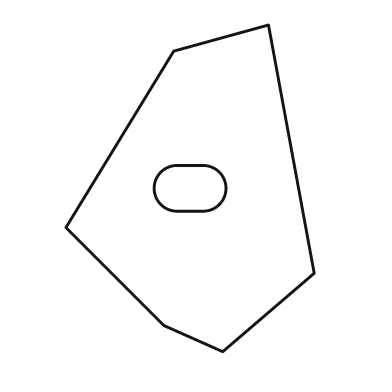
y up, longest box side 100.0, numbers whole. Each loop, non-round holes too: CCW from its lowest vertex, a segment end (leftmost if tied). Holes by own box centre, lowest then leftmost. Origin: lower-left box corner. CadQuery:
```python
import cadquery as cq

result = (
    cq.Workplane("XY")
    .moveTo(48.0, 0.0)
    .lineTo(76.0, 24.0)
    .lineTo(62.0, 100.0)
    .lineTo(33.0, 92.0)
    .lineTo(0.0, 38.0)
    .lineTo(30.0, 8.0)
    .close()
    .moveTo(34.0, 43.0)
    .lineTo(42.0, 43.0)
    .threePointArc((49.0, 50.0), (42.0, 57.0))
    .lineTo(34.0, 57.0)
    .threePointArc((27.0, 50.0), (34.0, 43.0))
    .close()
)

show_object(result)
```